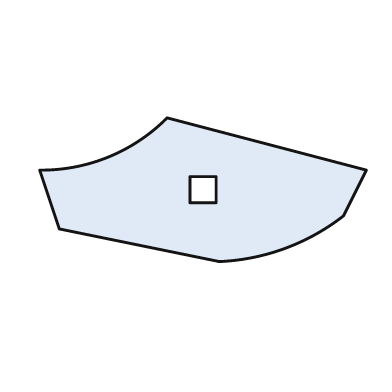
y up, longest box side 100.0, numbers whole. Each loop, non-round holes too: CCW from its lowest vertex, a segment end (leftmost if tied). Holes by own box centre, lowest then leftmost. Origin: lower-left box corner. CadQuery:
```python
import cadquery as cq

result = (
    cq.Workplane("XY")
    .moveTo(55.0, 0.0)
    .threePointArc((75.0, 4.0), (93.0, 14.0))
    .lineTo(100.0, 28.0)
    .lineTo(39.0, 44.0)
    .threePointArc((21.0, 32.0), (0.0, 28.0))
    .lineTo(6.0, 10.0)
    .close()
    .moveTo(46.0, 18.0)
    .lineTo(54.0, 18.0)
    .lineTo(54.0, 26.0)
    .lineTo(46.0, 26.0)
    .close()
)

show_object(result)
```